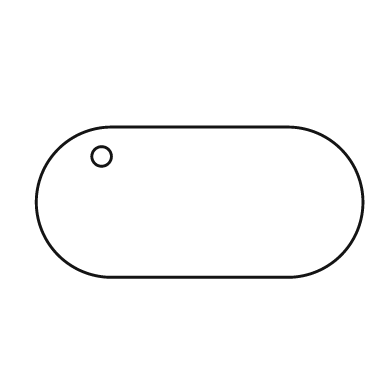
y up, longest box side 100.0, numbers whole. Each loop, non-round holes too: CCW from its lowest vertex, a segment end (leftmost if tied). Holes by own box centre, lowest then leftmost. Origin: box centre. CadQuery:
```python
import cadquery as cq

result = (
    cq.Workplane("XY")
    .moveTo(-27.0, -23.0)
    .lineTo(27.0, -23.0)
    .threePointArc((50.0, 0.0), (27.0, 23.0))
    .lineTo(-27.0, 23.0)
    .threePointArc((-50.0, 0.0), (-27.0, -23.0))
    .close()
    .moveTo(-30.0, 14.0)
    .circle(3.0)
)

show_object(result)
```